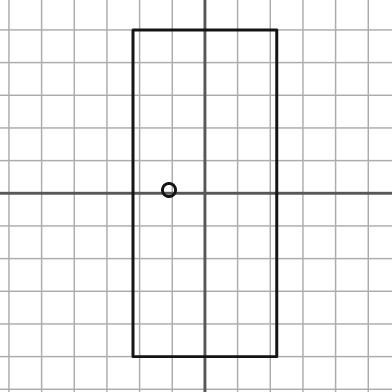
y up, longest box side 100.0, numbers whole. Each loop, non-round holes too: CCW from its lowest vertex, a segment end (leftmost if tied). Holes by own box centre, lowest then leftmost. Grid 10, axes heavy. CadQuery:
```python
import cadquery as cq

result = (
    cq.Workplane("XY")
    .moveTo(-22.0, -50.0)
    .lineTo(22.0, -50.0)
    .lineTo(22.0, 50.0)
    .lineTo(-22.0, 50.0)
    .close()
    .moveTo(-11.0, 1.0)
    .circle(2.0)
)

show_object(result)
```